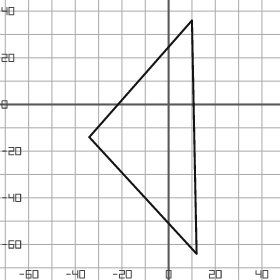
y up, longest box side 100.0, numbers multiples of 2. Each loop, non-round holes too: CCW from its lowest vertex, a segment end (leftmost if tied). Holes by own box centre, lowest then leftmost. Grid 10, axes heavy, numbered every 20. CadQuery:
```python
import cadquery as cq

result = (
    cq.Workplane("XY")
    .moveTo(12.0, -64.0)
    .lineTo(10.0, 36.0)
    .lineTo(-34.0, -14.0)
    .close()
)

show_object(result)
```